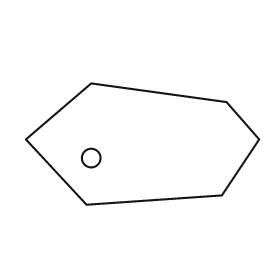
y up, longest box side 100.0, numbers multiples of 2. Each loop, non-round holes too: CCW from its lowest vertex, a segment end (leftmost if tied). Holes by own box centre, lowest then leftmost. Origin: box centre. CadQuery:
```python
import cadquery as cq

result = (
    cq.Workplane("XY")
    .moveTo(-24.0, -26.0)
    .lineTo(34.0, -22.0)
    .lineTo(50.0, 2.0)
    .lineTo(36.0, 18.0)
    .lineTo(-22.0, 26.0)
    .lineTo(-50.0, 2.0)
    .close()
    .moveTo(-22.0, -6.0)
    .circle(4.0)
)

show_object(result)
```